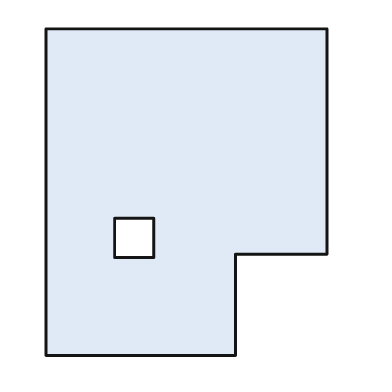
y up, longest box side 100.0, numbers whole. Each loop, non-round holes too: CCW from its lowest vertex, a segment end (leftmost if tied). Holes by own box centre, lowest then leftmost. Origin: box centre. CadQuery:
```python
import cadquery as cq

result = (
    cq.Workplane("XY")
    .moveTo(-43.0, -50.0)
    .lineTo(15.0, -50.0)
    .lineTo(15.0, -19.0)
    .lineTo(43.0, -19.0)
    .lineTo(43.0, 50.0)
    .lineTo(-43.0, 50.0)
    .close()
    .moveTo(-22.0, -20.0)
    .lineTo(-10.0, -20.0)
    .lineTo(-10.0, -8.0)
    .lineTo(-22.0, -8.0)
    .close()
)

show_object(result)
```